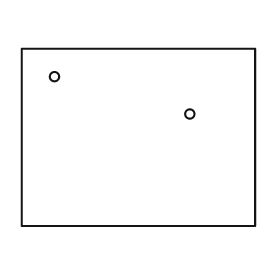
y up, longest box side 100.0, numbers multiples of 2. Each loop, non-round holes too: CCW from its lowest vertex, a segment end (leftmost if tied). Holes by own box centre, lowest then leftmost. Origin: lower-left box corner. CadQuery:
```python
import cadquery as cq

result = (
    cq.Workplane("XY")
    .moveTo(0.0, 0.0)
    .lineTo(100.0, 0.0)
    .lineTo(100.0, 76.0)
    .lineTo(0.0, 76.0)
    .close()
    .moveTo(72.0, 48.0)
    .circle(2.0)
    .moveTo(14.0, 64.0)
    .circle(2.0)
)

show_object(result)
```